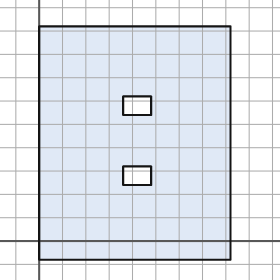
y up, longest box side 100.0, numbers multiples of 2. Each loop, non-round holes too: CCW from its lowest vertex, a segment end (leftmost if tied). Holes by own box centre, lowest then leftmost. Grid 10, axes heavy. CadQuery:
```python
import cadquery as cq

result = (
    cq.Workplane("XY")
    .moveTo(0.0, -8.0)
    .lineTo(82.0, -8.0)
    .lineTo(82.0, 92.0)
    .lineTo(0.0, 92.0)
    .close()
    .moveTo(36.0, 24.0)
    .lineTo(48.0, 24.0)
    .lineTo(48.0, 32.0)
    .lineTo(36.0, 32.0)
    .close()
    .moveTo(36.0, 54.0)
    .lineTo(48.0, 54.0)
    .lineTo(48.0, 62.0)
    .lineTo(36.0, 62.0)
    .close()
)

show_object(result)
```